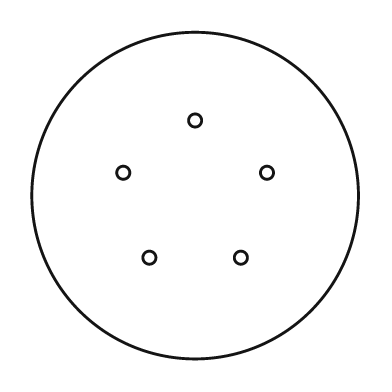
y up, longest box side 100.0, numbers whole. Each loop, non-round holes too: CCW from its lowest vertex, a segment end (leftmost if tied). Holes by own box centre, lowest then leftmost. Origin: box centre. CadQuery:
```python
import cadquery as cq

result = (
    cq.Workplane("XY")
    .moveTo(0.0, 0.0)
    .circle(50.0)
    .moveTo(-14.0, -19.0)
    .circle(2.0)
    .moveTo(14.0, -19.0)
    .circle(2.0)
    .moveTo(-22.0, 7.0)
    .circle(2.0)
    .moveTo(22.0, 7.0)
    .circle(2.0)
    .moveTo(0.0, 23.0)
    .circle(2.0)
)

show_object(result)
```